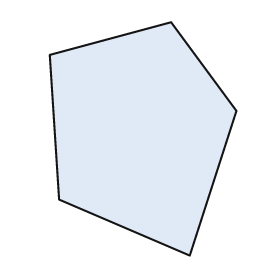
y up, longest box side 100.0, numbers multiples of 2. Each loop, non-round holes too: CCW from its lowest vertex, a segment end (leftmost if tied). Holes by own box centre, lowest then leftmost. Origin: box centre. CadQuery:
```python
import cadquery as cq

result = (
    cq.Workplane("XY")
    .moveTo(20.0, -50.0)
    .lineTo(40.0, 12.0)
    .lineTo(12.0, 50.0)
    .lineTo(-40.0, 36.0)
    .lineTo(-36.0, -26.0)
    .close()
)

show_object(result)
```